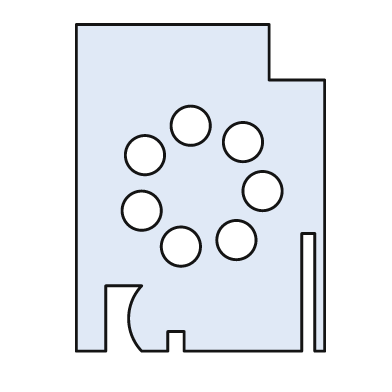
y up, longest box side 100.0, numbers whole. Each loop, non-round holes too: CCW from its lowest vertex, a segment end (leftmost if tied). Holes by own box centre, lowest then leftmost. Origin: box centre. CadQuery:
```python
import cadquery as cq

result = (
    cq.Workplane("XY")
    .moveTo(-38.0, -50.0)
    .lineTo(-29.0, -50.0)
    .lineTo(-29.0, -30.0)
    .lineTo(-18.0, -30.0)
    .threePointArc((-22.0, -40.0), (-18.0, -50.0))
    .lineTo(-10.0, -50.0)
    .lineTo(-10.0, -44.0)
    .lineTo(-5.0, -44.0)
    .lineTo(-5.0, -50.0)
    .lineTo(31.0, -50.0)
    .lineTo(31.0, -14.0)
    .lineTo(35.0, -14.0)
    .lineTo(35.0, -50.0)
    .lineTo(38.0, -50.0)
    .lineTo(38.0, 33.0)
    .lineTo(21.0, 33.0)
    .lineTo(21.0, 50.0)
    .lineTo(-38.0, 50.0)
    .close()
    .moveTo(-6.0, -18.0)
    .circle(6.0)
    .moveTo(11.0, -16.0)
    .circle(6.0)
    .moveTo(-18.0, -7.0)
    .circle(6.0)
    .moveTo(19.0, -1.0)
    .circle(6.0)
    .moveTo(-17.0, 10.0)
    .circle(6.0)
    .moveTo(13.0, 14.0)
    .circle(6.0)
    .moveTo(-3.0, 19.0)
    .circle(6.0)
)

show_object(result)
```